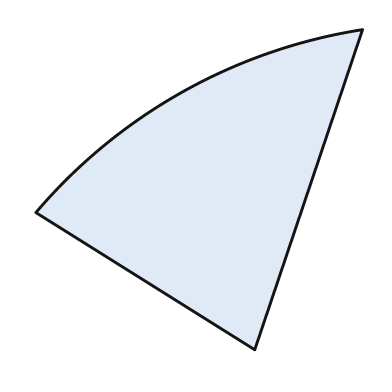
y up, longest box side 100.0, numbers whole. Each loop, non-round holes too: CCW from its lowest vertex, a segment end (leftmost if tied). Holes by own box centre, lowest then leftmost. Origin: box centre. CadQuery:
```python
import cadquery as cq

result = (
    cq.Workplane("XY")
    .moveTo(17.0, -49.0)
    .lineTo(50.0, 49.0)
    .threePointArc((-5.0, 30.0), (-50.0, -7.0))
    .close()
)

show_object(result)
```